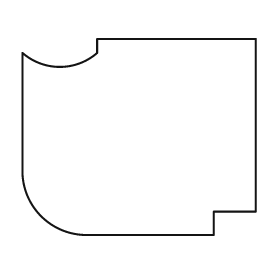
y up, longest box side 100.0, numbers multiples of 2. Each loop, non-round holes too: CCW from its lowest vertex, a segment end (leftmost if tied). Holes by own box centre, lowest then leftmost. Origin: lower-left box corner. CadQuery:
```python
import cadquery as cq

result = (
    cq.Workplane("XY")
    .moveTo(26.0, 0.0)
    .lineTo(82.0, 0.0)
    .lineTo(82.0, 10.0)
    .lineTo(100.0, 10.0)
    .lineTo(100.0, 84.0)
    .lineTo(32.0, 84.0)
    .lineTo(32.0, 78.0)
    .threePointArc((16.0, 72.0), (0.0, 78.0))
    .lineTo(0.0, 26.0)
    .threePointArc((8.0, 8.0), (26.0, 0.0))
    .close()
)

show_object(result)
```